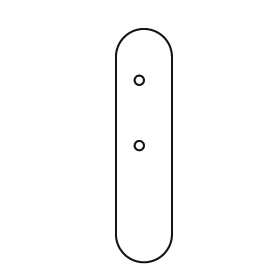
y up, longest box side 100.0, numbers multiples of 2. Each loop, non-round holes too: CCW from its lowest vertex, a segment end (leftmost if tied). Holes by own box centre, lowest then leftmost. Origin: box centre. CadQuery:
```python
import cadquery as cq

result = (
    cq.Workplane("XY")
    .moveTo(-12.0, -38.0)
    .threePointArc((0.0, -50.0), (12.0, -38.0))
    .lineTo(12.0, 38.0)
    .threePointArc((0.0, 50.0), (-12.0, 38.0))
    .close()
    .moveTo(-2.0, 0.0)
    .circle(2.0)
    .moveTo(-2.0, 28.0)
    .circle(2.0)
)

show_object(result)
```